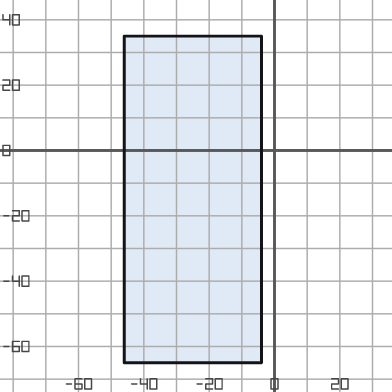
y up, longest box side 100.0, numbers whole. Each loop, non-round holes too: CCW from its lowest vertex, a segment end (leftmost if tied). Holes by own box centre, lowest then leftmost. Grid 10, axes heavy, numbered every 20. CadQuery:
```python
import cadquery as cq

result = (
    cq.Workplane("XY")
    .moveTo(-46.0, -65.0)
    .lineTo(-4.0, -65.0)
    .lineTo(-4.0, 35.0)
    .lineTo(-46.0, 35.0)
    .close()
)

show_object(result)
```